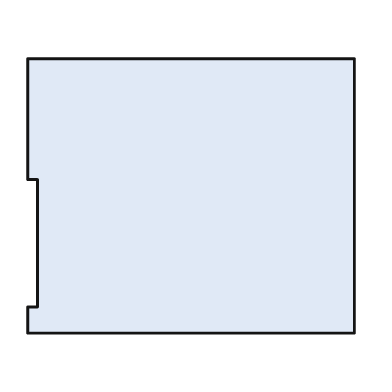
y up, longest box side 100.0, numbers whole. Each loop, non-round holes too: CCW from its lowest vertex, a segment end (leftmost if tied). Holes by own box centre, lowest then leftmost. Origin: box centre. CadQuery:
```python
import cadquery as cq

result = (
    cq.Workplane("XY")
    .moveTo(-50.0, -42.0)
    .lineTo(50.0, -42.0)
    .lineTo(50.0, 42.0)
    .lineTo(-50.0, 42.0)
    .lineTo(-50.0, 5.0)
    .lineTo(-47.0, 5.0)
    .lineTo(-47.0, -34.0)
    .lineTo(-50.0, -34.0)
    .close()
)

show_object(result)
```